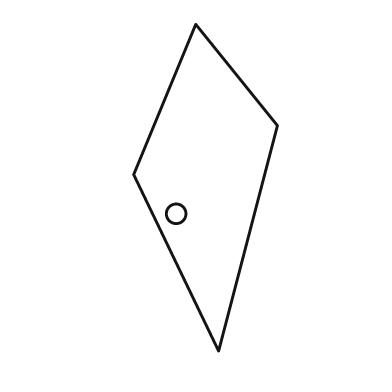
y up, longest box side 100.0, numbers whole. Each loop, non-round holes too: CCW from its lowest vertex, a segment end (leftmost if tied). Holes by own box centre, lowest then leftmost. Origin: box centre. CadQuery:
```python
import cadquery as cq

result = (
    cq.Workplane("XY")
    .moveTo(4.0, -50.0)
    .lineTo(22.0, 19.0)
    .lineTo(-3.0, 50.0)
    .lineTo(-22.0, 4.0)
    .close()
    .moveTo(-9.0, -8.0)
    .circle(3.0)
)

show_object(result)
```